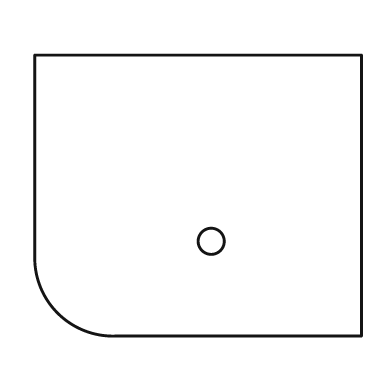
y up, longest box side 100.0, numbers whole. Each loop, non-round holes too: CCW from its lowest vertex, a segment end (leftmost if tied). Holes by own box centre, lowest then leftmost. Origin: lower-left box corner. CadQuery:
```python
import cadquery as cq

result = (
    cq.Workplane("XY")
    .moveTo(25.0, 0.0)
    .lineTo(100.0, 0.0)
    .lineTo(100.0, 86.0)
    .lineTo(0.0, 86.0)
    .lineTo(0.0, 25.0)
    .threePointArc((7.0, 7.0), (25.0, 0.0))
    .close()
    .moveTo(54.0, 29.0)
    .circle(4.0)
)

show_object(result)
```